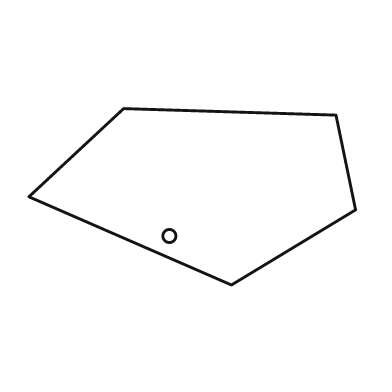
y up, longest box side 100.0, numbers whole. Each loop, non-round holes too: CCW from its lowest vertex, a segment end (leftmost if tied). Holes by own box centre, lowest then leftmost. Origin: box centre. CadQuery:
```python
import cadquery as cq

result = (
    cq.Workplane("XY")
    .moveTo(12.0, -27.0)
    .lineTo(50.0, -4.0)
    .lineTo(44.0, 25.0)
    .lineTo(-21.0, 27.0)
    .lineTo(-50.0, 0.0)
    .close()
    .moveTo(-7.0, -12.0)
    .circle(2.0)
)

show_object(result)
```